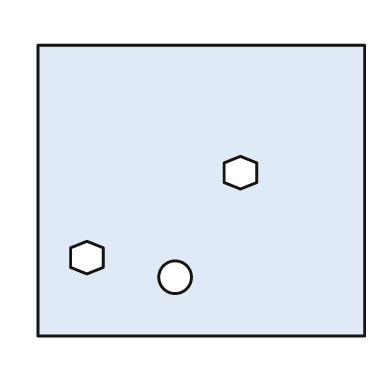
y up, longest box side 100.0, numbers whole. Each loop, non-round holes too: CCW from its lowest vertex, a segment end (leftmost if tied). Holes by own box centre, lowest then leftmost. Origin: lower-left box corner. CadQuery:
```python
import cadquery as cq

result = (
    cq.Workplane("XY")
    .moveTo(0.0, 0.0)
    .lineTo(100.0, 0.0)
    .lineTo(100.0, 89.0)
    .lineTo(0.0, 89.0)
    .close()
    .moveTo(42.0, 18.0)
    .circle(5.0)
    .moveTo(15.0, 19.0)
    .lineTo(20.0, 21.0)
    .lineTo(20.0, 27.0)
    .lineTo(15.0, 29.0)
    .lineTo(10.0, 27.0)
    .lineTo(10.0, 21.0)
    .close()
    .moveTo(62.0, 45.0)
    .lineTo(67.0, 47.0)
    .lineTo(67.0, 53.0)
    .lineTo(62.0, 55.0)
    .lineTo(57.0, 53.0)
    .lineTo(57.0, 47.0)
    .close()
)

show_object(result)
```